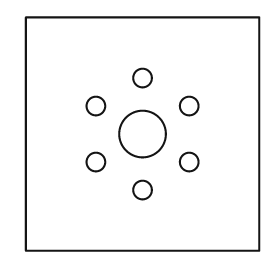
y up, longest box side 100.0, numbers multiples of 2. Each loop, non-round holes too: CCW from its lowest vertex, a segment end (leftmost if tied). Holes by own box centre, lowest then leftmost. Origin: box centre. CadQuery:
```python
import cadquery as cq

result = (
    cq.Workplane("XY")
    .moveTo(-50.0, -50.0)
    .lineTo(50.0, -50.0)
    .lineTo(50.0, 50.0)
    .lineTo(-50.0, 50.0)
    .close()
    .moveTo(0.0, -24.0)
    .circle(4.0)
    .moveTo(-20.0, -12.0)
    .circle(4.0)
    .moveTo(20.0, -12.0)
    .circle(4.0)
    .moveTo(0.0, 0.0)
    .circle(10.0)
    .moveTo(-20.0, 12.0)
    .circle(4.0)
    .moveTo(20.0, 12.0)
    .circle(4.0)
    .moveTo(0.0, 24.0)
    .circle(4.0)
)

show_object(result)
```